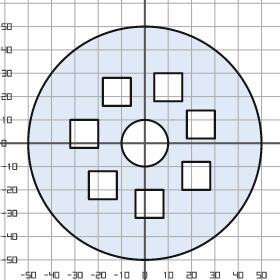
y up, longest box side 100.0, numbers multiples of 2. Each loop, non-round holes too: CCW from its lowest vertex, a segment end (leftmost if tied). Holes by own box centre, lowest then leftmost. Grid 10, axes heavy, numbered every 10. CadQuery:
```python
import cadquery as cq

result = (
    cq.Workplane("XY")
    .moveTo(0.0, 0.0)
    .circle(50.0)
    .moveTo(-4.0, -32.0)
    .lineTo(8.0, -32.0)
    .lineTo(8.0, -20.0)
    .lineTo(-4.0, -20.0)
    .close()
    .moveTo(-24.0, -24.0)
    .lineTo(-12.0, -24.0)
    .lineTo(-12.0, -12.0)
    .lineTo(-24.0, -12.0)
    .close()
    .moveTo(16.0, -20.0)
    .lineTo(28.0, -20.0)
    .lineTo(28.0, -8.0)
    .lineTo(16.0, -8.0)
    .close()
    .moveTo(0.0, 0.0)
    .circle(10.0)
    .moveTo(-32.0, -2.0)
    .lineTo(-20.0, -2.0)
    .lineTo(-20.0, 10.0)
    .lineTo(-32.0, 10.0)
    .close()
    .moveTo(18.0, 2.0)
    .lineTo(30.0, 2.0)
    .lineTo(30.0, 14.0)
    .lineTo(18.0, 14.0)
    .close()
    .moveTo(-18.0, 16.0)
    .lineTo(-6.0, 16.0)
    .lineTo(-6.0, 28.0)
    .lineTo(-18.0, 28.0)
    .close()
    .moveTo(4.0, 18.0)
    .lineTo(16.0, 18.0)
    .lineTo(16.0, 30.0)
    .lineTo(4.0, 30.0)
    .close()
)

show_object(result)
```